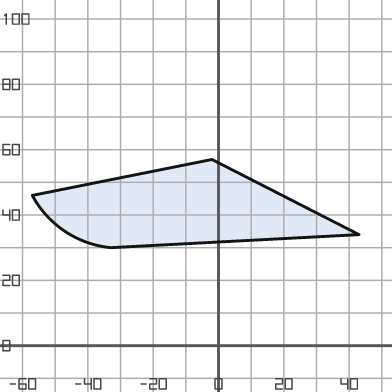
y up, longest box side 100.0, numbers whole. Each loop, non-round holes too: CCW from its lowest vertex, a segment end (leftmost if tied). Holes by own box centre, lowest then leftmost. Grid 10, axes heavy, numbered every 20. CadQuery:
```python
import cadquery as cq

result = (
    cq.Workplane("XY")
    .moveTo(-33.0, 30.0)
    .lineTo(43.0, 34.0)
    .lineTo(-2.0, 57.0)
    .lineTo(-57.0, 46.0)
    .threePointArc((-47.0, 35.0), (-33.0, 30.0))
    .close()
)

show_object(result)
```